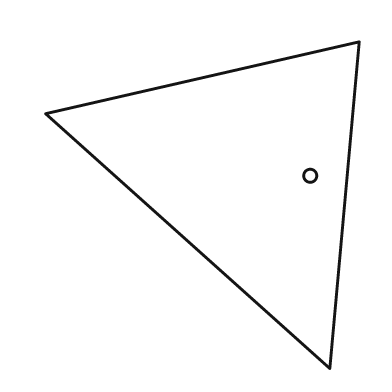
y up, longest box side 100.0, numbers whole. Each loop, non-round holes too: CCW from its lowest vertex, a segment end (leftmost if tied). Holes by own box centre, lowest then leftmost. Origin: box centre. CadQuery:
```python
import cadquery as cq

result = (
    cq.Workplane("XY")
    .moveTo(39.0, -50.0)
    .lineTo(48.0, 50.0)
    .lineTo(-48.0, 28.0)
    .close()
    .moveTo(33.0, 9.0)
    .circle(2.0)
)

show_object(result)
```